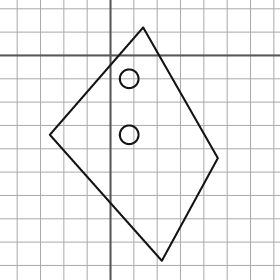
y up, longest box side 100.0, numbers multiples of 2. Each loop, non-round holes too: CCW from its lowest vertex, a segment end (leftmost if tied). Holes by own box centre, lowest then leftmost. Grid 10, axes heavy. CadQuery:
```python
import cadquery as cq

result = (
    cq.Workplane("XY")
    .moveTo(22.0, -88.0)
    .lineTo(46.0, -44.0)
    .lineTo(14.0, 12.0)
    .lineTo(-26.0, -34.0)
    .close()
    .moveTo(8.0, -34.0)
    .circle(4.0)
    .moveTo(8.0, -10.0)
    .circle(4.0)
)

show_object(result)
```